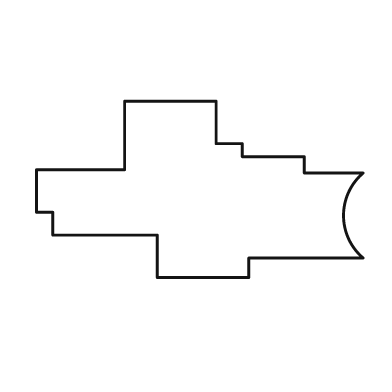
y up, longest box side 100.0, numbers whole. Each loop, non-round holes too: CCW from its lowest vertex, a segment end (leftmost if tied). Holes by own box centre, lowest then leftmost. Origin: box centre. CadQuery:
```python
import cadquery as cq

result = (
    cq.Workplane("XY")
    .moveTo(-13.0, -27.0)
    .lineTo(15.0, -27.0)
    .lineTo(15.0, -21.0)
    .lineTo(50.0, -21.0)
    .threePointArc((44.0, -8.0), (50.0, 5.0))
    .lineTo(32.0, 5.0)
    .lineTo(32.0, 10.0)
    .lineTo(13.0, 10.0)
    .lineTo(13.0, 14.0)
    .lineTo(5.0, 14.0)
    .lineTo(5.0, 27.0)
    .lineTo(-23.0, 27.0)
    .lineTo(-23.0, 6.0)
    .lineTo(-50.0, 6.0)
    .lineTo(-50.0, -7.0)
    .lineTo(-45.0, -7.0)
    .lineTo(-45.0, -14.0)
    .lineTo(-13.0, -14.0)
    .close()
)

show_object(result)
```